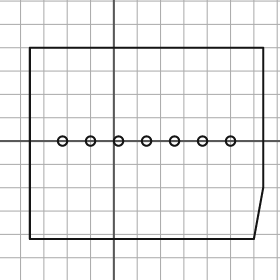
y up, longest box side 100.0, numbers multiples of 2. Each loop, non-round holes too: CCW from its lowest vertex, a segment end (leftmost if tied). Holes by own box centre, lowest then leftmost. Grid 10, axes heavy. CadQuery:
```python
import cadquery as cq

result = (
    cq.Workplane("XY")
    .moveTo(-36.0, -42.0)
    .lineTo(60.0, -42.0)
    .lineTo(64.0, -20.0)
    .lineTo(64.0, 40.0)
    .lineTo(-36.0, 40.0)
    .close()
    .moveTo(-22.0, 0.0)
    .circle(2.0)
    .moveTo(-10.0, 0.0)
    .circle(2.0)
    .moveTo(2.0, 0.0)
    .circle(2.0)
    .moveTo(14.0, 0.0)
    .circle(2.0)
    .moveTo(26.0, 0.0)
    .circle(2.0)
    .moveTo(38.0, 0.0)
    .circle(2.0)
    .moveTo(50.0, 0.0)
    .circle(2.0)
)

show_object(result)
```